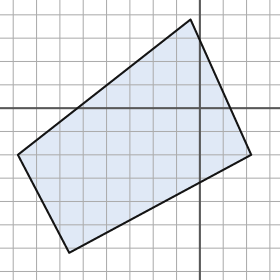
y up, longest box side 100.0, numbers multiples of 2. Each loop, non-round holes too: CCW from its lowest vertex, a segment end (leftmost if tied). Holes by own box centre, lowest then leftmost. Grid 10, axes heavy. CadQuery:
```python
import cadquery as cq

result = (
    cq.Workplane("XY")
    .moveTo(-56.0, -62.0)
    .lineTo(22.0, -20.0)
    .lineTo(-4.0, 38.0)
    .lineTo(-78.0, -20.0)
    .close()
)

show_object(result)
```